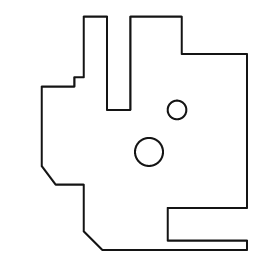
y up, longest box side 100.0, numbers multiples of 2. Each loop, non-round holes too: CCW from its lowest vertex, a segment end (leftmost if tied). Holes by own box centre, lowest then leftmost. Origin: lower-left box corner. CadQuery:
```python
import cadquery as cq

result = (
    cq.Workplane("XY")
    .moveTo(26.0, 0.0)
    .lineTo(88.0, 0.0)
    .lineTo(88.0, 4.0)
    .lineTo(54.0, 4.0)
    .lineTo(54.0, 18.0)
    .lineTo(88.0, 18.0)
    .lineTo(88.0, 84.0)
    .lineTo(60.0, 84.0)
    .lineTo(60.0, 100.0)
    .lineTo(38.0, 100.0)
    .lineTo(38.0, 60.0)
    .lineTo(28.0, 60.0)
    .lineTo(28.0, 100.0)
    .lineTo(18.0, 100.0)
    .lineTo(18.0, 74.0)
    .lineTo(14.0, 74.0)
    .lineTo(14.0, 70.0)
    .lineTo(0.0, 70.0)
    .lineTo(0.0, 36.0)
    .lineTo(6.0, 28.0)
    .lineTo(18.0, 28.0)
    .lineTo(18.0, 8.0)
    .close()
    .moveTo(46.0, 42.0)
    .circle(6.0)
    .moveTo(58.0, 60.0)
    .circle(4.0)
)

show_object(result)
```